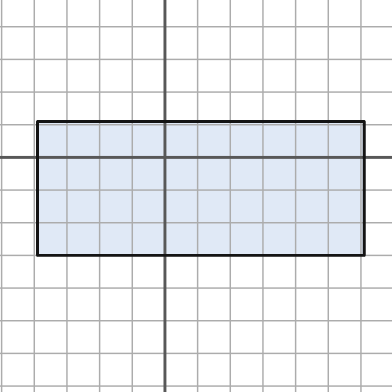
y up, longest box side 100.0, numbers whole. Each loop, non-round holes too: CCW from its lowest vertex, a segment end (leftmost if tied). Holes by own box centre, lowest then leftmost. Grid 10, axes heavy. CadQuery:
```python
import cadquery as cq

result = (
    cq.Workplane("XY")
    .moveTo(-39.0, -30.0)
    .lineTo(61.0, -30.0)
    .lineTo(61.0, 11.0)
    .lineTo(-39.0, 11.0)
    .close()
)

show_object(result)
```